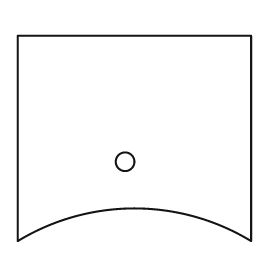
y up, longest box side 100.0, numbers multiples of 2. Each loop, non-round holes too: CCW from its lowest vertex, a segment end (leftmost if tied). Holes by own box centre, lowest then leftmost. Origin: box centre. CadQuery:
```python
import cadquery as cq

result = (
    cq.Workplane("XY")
    .moveTo(-50.0, -44.0)
    .threePointArc((0.0, -30.0), (50.0, -44.0))
    .lineTo(50.0, 44.0)
    .lineTo(-50.0, 44.0)
    .close()
    .moveTo(-4.0, -10.0)
    .circle(4.0)
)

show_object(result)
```